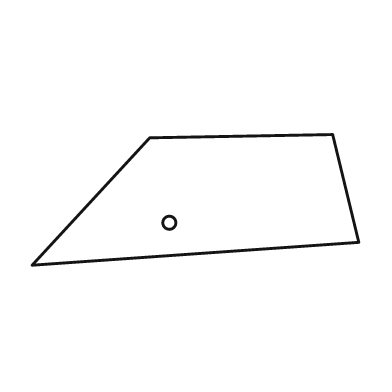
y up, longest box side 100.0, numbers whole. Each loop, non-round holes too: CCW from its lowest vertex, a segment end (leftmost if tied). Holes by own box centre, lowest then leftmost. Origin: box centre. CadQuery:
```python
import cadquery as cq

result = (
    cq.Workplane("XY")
    .moveTo(-50.0, -20.0)
    .lineTo(50.0, -13.0)
    .lineTo(42.0, 20.0)
    .lineTo(-14.0, 19.0)
    .close()
    .moveTo(-8.0, -7.0)
    .circle(2.0)
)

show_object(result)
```